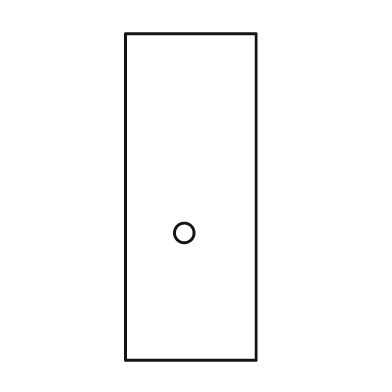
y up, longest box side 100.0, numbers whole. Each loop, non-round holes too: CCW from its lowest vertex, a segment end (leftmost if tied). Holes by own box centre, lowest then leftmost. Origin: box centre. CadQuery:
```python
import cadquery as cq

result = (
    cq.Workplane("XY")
    .moveTo(-20.0, -50.0)
    .lineTo(20.0, -50.0)
    .lineTo(20.0, 50.0)
    .lineTo(-20.0, 50.0)
    .close()
    .moveTo(-2.0, -11.0)
    .circle(3.0)
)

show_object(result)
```